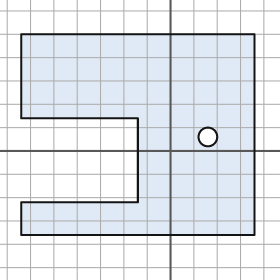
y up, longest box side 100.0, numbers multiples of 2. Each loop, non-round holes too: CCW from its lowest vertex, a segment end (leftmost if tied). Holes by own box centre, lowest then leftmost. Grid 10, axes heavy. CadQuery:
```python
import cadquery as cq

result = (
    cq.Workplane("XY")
    .moveTo(-64.0, -36.0)
    .lineTo(36.0, -36.0)
    .lineTo(36.0, 50.0)
    .lineTo(-64.0, 50.0)
    .lineTo(-64.0, 14.0)
    .lineTo(-14.0, 14.0)
    .lineTo(-14.0, -22.0)
    .lineTo(-64.0, -22.0)
    .close()
    .moveTo(16.0, 6.0)
    .circle(4.0)
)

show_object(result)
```